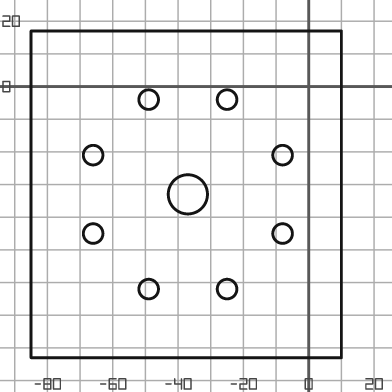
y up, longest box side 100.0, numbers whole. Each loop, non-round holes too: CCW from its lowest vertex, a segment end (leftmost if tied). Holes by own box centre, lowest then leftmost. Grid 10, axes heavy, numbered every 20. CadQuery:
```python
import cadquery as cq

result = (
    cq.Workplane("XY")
    .moveTo(-85.0, -83.0)
    .lineTo(10.0, -83.0)
    .lineTo(10.0, 17.0)
    .lineTo(-85.0, 17.0)
    .close()
    .moveTo(-49.0, -62.0)
    .circle(3.0)
    .moveTo(-25.0, -62.0)
    .circle(3.0)
    .moveTo(-66.0, -45.0)
    .circle(3.0)
    .moveTo(-8.0, -45.0)
    .circle(3.0)
    .moveTo(-37.0, -33.0)
    .circle(6.0)
    .moveTo(-66.0, -21.0)
    .circle(3.0)
    .moveTo(-8.0, -21.0)
    .circle(3.0)
    .moveTo(-49.0, -4.0)
    .circle(3.0)
    .moveTo(-25.0, -4.0)
    .circle(3.0)
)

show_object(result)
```